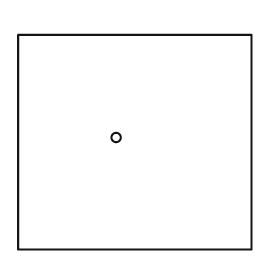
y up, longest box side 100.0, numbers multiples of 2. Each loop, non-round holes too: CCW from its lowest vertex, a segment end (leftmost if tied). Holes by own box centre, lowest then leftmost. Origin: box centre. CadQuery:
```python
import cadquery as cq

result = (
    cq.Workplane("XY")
    .moveTo(-50.0, -46.0)
    .lineTo(50.0, -46.0)
    .lineTo(50.0, 46.0)
    .lineTo(-50.0, 46.0)
    .close()
    .moveTo(-8.0, 2.0)
    .circle(2.0)
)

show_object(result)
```